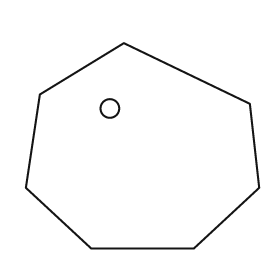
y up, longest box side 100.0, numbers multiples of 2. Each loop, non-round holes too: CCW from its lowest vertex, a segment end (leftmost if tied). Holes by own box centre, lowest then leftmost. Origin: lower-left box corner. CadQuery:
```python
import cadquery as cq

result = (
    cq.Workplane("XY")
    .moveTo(28.0, 0.0)
    .lineTo(72.0, 0.0)
    .lineTo(100.0, 26.0)
    .lineTo(96.0, 62.0)
    .lineTo(42.0, 88.0)
    .lineTo(6.0, 66.0)
    .lineTo(0.0, 26.0)
    .close()
    .moveTo(36.0, 60.0)
    .circle(4.0)
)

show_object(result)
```